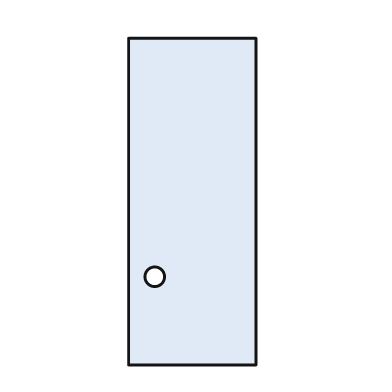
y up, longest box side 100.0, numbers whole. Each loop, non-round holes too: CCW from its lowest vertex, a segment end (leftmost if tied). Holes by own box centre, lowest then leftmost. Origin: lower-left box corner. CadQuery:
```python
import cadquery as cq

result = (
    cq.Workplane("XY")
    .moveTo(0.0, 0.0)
    .lineTo(39.0, 0.0)
    .lineTo(39.0, 100.0)
    .lineTo(0.0, 100.0)
    .close()
    .moveTo(8.0, 27.0)
    .circle(3.0)
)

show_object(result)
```